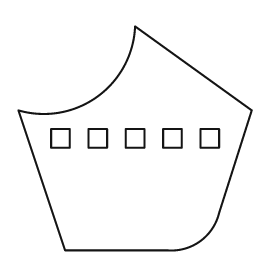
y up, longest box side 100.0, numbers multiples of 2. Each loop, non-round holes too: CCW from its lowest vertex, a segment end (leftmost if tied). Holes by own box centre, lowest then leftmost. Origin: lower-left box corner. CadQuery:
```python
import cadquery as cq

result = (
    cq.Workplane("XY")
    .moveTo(20.0, 0.0)
    .lineTo(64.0, 0.0)
    .threePointArc((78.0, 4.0), (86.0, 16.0))
    .lineTo(100.0, 60.0)
    .lineTo(50.0, 96.0)
    .threePointArc((34.0, 66.0), (0.0, 60.0))
    .close()
    .moveTo(14.0, 44.0)
    .lineTo(22.0, 44.0)
    .lineTo(22.0, 52.0)
    .lineTo(14.0, 52.0)
    .close()
    .moveTo(30.0, 44.0)
    .lineTo(38.0, 44.0)
    .lineTo(38.0, 52.0)
    .lineTo(30.0, 52.0)
    .close()
    .moveTo(46.0, 44.0)
    .lineTo(54.0, 44.0)
    .lineTo(54.0, 52.0)
    .lineTo(46.0, 52.0)
    .close()
    .moveTo(62.0, 44.0)
    .lineTo(70.0, 44.0)
    .lineTo(70.0, 52.0)
    .lineTo(62.0, 52.0)
    .close()
    .moveTo(78.0, 44.0)
    .lineTo(86.0, 44.0)
    .lineTo(86.0, 52.0)
    .lineTo(78.0, 52.0)
    .close()
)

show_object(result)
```